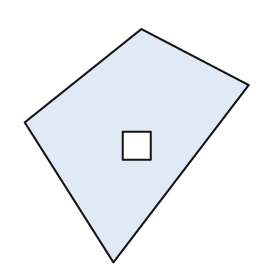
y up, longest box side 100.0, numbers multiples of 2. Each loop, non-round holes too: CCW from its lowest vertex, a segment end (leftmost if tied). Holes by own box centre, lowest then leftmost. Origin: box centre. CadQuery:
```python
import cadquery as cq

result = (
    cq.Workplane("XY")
    .moveTo(-10.0, -50.0)
    .lineTo(48.0, 26.0)
    .lineTo(2.0, 50.0)
    .lineTo(-48.0, 10.0)
    .close()
    .moveTo(-6.0, -6.0)
    .lineTo(6.0, -6.0)
    .lineTo(6.0, 6.0)
    .lineTo(-6.0, 6.0)
    .close()
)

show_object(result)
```